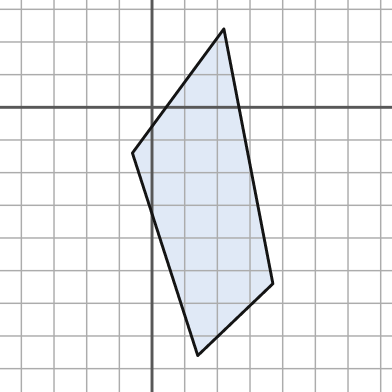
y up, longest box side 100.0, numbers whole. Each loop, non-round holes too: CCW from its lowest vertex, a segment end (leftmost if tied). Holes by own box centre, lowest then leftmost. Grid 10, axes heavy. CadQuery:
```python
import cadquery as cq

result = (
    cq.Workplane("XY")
    .moveTo(14.0, -76.0)
    .lineTo(37.0, -54.0)
    .lineTo(22.0, 24.0)
    .lineTo(-6.0, -14.0)
    .close()
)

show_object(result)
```